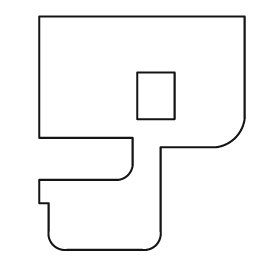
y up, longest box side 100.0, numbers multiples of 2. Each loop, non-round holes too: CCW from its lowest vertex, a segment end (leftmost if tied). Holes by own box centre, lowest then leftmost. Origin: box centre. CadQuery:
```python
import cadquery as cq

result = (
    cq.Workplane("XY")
    .moveTo(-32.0, -50.0)
    .lineTo(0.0, -50.0)
    .threePointArc((6.0, -48.0), (8.0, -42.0))
    .lineTo(8.0, -6.0)
    .lineTo(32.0, -6.0)
    .threePointArc((40.0, -2.0), (44.0, 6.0))
    .lineTo(44.0, 50.0)
    .lineTo(-44.0, 50.0)
    .lineTo(-44.0, -2.0)
    .lineTo(-4.0, -2.0)
    .lineTo(-4.0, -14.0)
    .threePointArc((-6.0, -18.0), (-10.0, -20.0))
    .lineTo(-44.0, -20.0)
    .lineTo(-44.0, -30.0)
    .lineTo(-40.0, -30.0)
    .lineTo(-40.0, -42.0)
    .threePointArc((-38.0, -48.0), (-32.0, -50.0))
    .close()
    .moveTo(-2.0, 6.0)
    .lineTo(14.0, 6.0)
    .lineTo(14.0, 26.0)
    .lineTo(-2.0, 26.0)
    .close()
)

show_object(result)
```